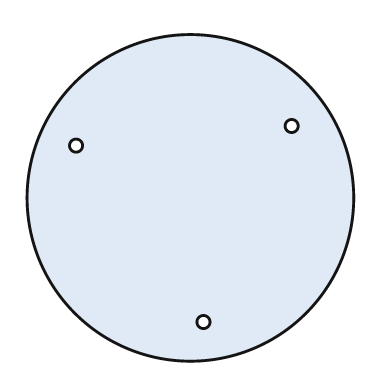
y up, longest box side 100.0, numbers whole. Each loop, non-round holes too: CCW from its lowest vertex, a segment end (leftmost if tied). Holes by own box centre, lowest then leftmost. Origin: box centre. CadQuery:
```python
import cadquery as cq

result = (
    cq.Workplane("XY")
    .moveTo(0.0, 0.0)
    .circle(50.0)
    .moveTo(4.0, -38.0)
    .circle(2.0)
    .moveTo(-35.0, 16.0)
    .circle(2.0)
    .moveTo(31.0, 22.0)
    .circle(2.0)
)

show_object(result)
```